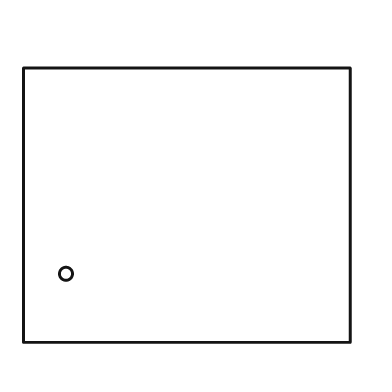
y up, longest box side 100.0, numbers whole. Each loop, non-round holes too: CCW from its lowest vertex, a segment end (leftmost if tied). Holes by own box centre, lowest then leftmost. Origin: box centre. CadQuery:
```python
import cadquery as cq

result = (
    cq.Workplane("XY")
    .moveTo(-50.0, -42.0)
    .lineTo(50.0, -42.0)
    .lineTo(50.0, 42.0)
    .lineTo(-50.0, 42.0)
    .close()
    .moveTo(-37.0, -21.0)
    .circle(2.0)
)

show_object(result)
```